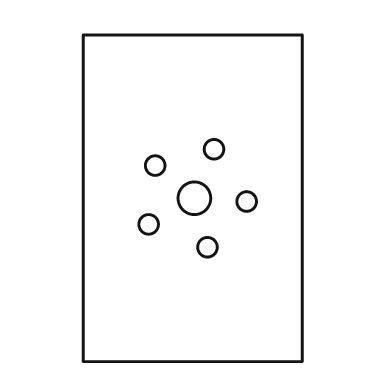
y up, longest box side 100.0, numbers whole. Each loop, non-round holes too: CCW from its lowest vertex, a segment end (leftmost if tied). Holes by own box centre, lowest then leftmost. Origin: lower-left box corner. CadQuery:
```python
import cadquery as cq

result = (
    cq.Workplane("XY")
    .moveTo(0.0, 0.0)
    .lineTo(67.0, 0.0)
    .lineTo(67.0, 100.0)
    .lineTo(0.0, 100.0)
    .close()
    .moveTo(38.0, 35.0)
    .circle(3.0)
    .moveTo(20.0, 42.0)
    .circle(3.0)
    .moveTo(50.0, 49.0)
    .circle(3.0)
    .moveTo(34.0, 50.0)
    .circle(5.0)
    .moveTo(22.0, 60.0)
    .circle(3.0)
    .moveTo(40.0, 65.0)
    .circle(3.0)
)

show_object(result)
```